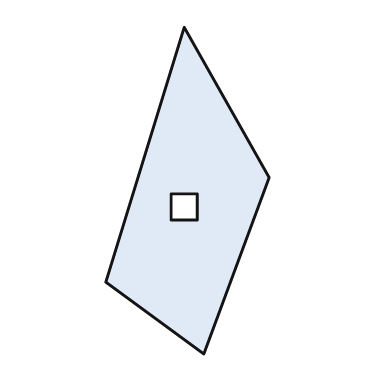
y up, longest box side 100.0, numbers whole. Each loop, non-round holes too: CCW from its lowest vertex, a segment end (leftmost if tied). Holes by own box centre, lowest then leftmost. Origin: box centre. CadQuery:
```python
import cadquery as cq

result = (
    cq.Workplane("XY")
    .moveTo(5.0, -50.0)
    .lineTo(25.0, 4.0)
    .lineTo(-1.0, 50.0)
    .lineTo(-25.0, -28.0)
    .close()
    .moveTo(-5.0, -9.0)
    .lineTo(3.0, -9.0)
    .lineTo(3.0, -1.0)
    .lineTo(-5.0, -1.0)
    .close()
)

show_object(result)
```